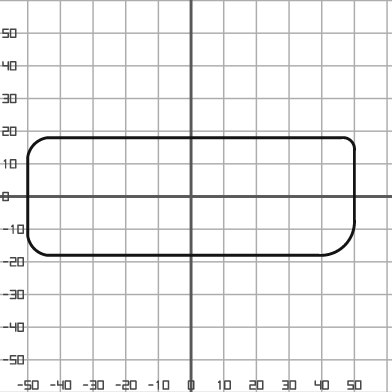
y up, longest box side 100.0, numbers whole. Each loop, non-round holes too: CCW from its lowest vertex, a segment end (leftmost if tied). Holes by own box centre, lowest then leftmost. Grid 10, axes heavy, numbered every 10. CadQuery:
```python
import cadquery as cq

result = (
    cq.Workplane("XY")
    .moveTo(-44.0, -18.0)
    .lineTo(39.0, -18.0)
    .threePointArc((47.0, -15.0), (50.0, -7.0))
    .lineTo(50.0, 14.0)
    .threePointArc((49.0, 17.0), (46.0, 18.0))
    .lineTo(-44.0, 18.0)
    .threePointArc((-48.0, 16.0), (-50.0, 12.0))
    .lineTo(-50.0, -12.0)
    .threePointArc((-48.0, -16.0), (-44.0, -18.0))
    .close()
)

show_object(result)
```